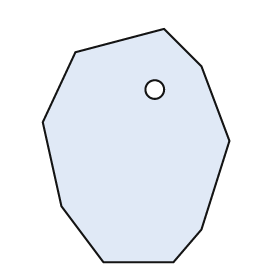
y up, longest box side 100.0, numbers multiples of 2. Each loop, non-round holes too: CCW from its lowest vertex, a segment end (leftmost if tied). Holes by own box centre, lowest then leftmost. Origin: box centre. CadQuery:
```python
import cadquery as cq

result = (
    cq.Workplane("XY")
    .moveTo(-14.0, -50.0)
    .lineTo(16.0, -50.0)
    .lineTo(28.0, -36.0)
    .lineTo(40.0, 2.0)
    .lineTo(28.0, 34.0)
    .lineTo(12.0, 50.0)
    .lineTo(-26.0, 40.0)
    .lineTo(-40.0, 10.0)
    .lineTo(-32.0, -26.0)
    .close()
    .moveTo(8.0, 24.0)
    .circle(4.0)
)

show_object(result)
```